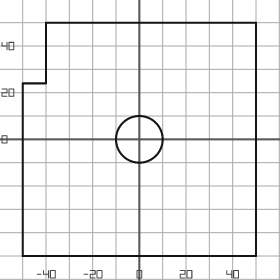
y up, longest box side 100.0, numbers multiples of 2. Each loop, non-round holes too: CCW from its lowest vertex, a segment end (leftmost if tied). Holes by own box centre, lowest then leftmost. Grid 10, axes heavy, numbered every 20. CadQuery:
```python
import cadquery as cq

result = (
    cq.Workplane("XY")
    .moveTo(-50.0, -50.0)
    .lineTo(50.0, -50.0)
    .lineTo(50.0, 50.0)
    .lineTo(-40.0, 50.0)
    .lineTo(-40.0, 24.0)
    .lineTo(-50.0, 24.0)
    .close()
    .moveTo(0.0, 0.0)
    .circle(10.0)
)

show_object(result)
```